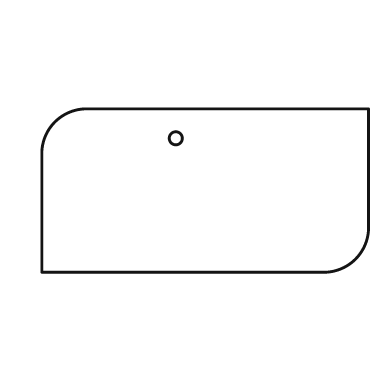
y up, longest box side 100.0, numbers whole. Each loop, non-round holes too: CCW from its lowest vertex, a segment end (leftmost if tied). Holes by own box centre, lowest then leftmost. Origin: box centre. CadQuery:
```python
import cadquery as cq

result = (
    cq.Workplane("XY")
    .moveTo(-50.0, -25.0)
    .lineTo(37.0, -25.0)
    .threePointArc((46.0, -21.0), (50.0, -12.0))
    .lineTo(50.0, 25.0)
    .lineTo(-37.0, 25.0)
    .threePointArc((-46.0, 21.0), (-50.0, 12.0))
    .close()
    .moveTo(-9.0, 16.0)
    .circle(2.0)
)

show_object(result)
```